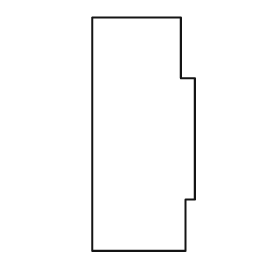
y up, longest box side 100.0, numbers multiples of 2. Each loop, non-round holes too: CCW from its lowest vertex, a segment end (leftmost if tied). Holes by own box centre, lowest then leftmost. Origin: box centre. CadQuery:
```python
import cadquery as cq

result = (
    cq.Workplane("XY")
    .moveTo(-22.0, -50.0)
    .lineTo(18.0, -50.0)
    .lineTo(18.0, -28.0)
    .lineTo(22.0, -28.0)
    .lineTo(22.0, 24.0)
    .lineTo(16.0, 24.0)
    .lineTo(16.0, 50.0)
    .lineTo(-22.0, 50.0)
    .close()
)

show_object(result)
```